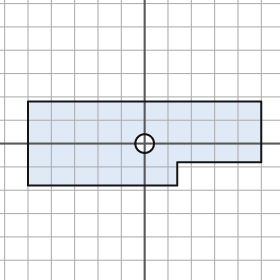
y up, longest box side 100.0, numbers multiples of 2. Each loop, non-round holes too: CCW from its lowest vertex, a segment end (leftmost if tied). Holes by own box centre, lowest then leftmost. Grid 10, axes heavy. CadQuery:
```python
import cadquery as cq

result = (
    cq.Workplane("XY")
    .moveTo(-50.0, -18.0)
    .lineTo(14.0, -18.0)
    .lineTo(14.0, -8.0)
    .lineTo(50.0, -8.0)
    .lineTo(50.0, 18.0)
    .lineTo(-50.0, 18.0)
    .close()
    .moveTo(0.0, 0.0)
    .circle(4.0)
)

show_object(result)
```